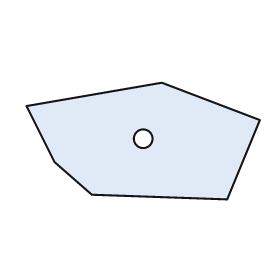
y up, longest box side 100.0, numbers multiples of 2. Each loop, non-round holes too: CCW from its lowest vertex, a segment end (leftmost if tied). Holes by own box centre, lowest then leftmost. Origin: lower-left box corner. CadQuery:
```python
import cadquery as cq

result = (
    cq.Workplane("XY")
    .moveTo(86.0, 0.0)
    .lineTo(100.0, 34.0)
    .lineTo(58.0, 50.0)
    .lineTo(0.0, 40.0)
    .lineTo(12.0, 16.0)
    .lineTo(28.0, 2.0)
    .close()
    .moveTo(50.0, 26.0)
    .circle(4.0)
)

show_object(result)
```